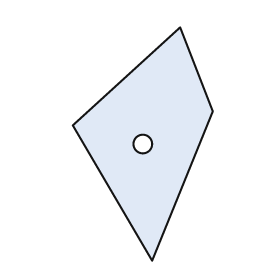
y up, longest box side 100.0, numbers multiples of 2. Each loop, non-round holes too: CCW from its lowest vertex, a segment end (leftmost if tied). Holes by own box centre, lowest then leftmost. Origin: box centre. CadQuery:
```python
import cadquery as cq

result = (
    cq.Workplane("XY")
    .moveTo(4.0, -50.0)
    .lineTo(30.0, 14.0)
    .lineTo(16.0, 50.0)
    .lineTo(-30.0, 8.0)
    .close()
    .moveTo(0.0, 0.0)
    .circle(4.0)
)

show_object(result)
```